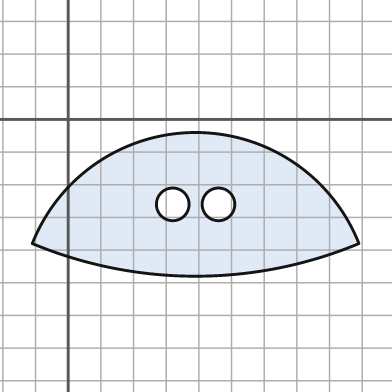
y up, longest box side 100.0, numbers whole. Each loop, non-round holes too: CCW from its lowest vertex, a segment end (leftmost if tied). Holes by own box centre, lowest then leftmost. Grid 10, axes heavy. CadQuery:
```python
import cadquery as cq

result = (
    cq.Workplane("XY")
    .moveTo(-11.0, -38.0)
    .threePointArc((39.0, -48.0), (89.0, -38.0))
    .threePointArc((39.0, -4.0), (-11.0, -38.0))
    .close()
    .moveTo(32.0, -26.0)
    .circle(5.0)
    .moveTo(46.0, -26.0)
    .circle(5.0)
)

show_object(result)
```